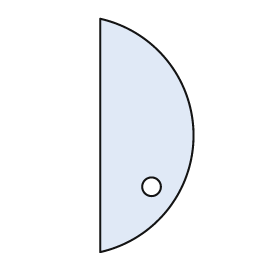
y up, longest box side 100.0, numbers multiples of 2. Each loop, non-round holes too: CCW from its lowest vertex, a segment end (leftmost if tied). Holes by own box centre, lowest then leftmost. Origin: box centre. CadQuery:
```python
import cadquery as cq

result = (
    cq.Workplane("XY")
    .moveTo(-20.0, -50.0)
    .threePointArc((20.0, 0.0), (-20.0, 50.0))
    .close()
    .moveTo(2.0, -22.0)
    .circle(4.0)
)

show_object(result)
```